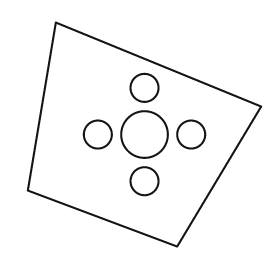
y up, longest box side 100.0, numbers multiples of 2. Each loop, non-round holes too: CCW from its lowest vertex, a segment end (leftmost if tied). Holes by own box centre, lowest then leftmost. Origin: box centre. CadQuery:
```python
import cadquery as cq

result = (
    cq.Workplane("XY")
    .moveTo(14.0, -48.0)
    .lineTo(50.0, 12.0)
    .lineTo(-38.0, 48.0)
    .lineTo(-50.0, -24.0)
    .close()
    .moveTo(0.0, -20.0)
    .circle(6.0)
    .moveTo(-20.0, 0.0)
    .circle(6.0)
    .moveTo(0.0, 0.0)
    .circle(10.0)
    .moveTo(20.0, 0.0)
    .circle(6.0)
    .moveTo(0.0, 20.0)
    .circle(6.0)
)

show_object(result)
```